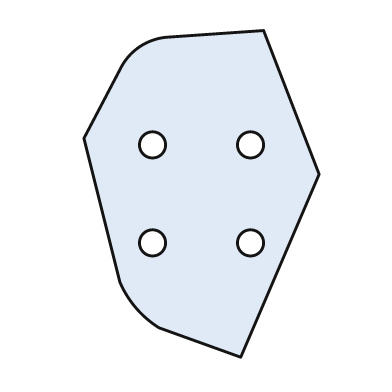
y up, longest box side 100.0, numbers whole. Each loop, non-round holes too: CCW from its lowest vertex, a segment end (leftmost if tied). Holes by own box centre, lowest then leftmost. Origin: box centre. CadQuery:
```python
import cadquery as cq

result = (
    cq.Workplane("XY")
    .moveTo(12.0, -50.0)
    .lineTo(36.0, 6.0)
    .lineTo(19.0, 50.0)
    .lineTo(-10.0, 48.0)
    .threePointArc((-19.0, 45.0), (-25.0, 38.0))
    .lineTo(-36.0, 17.0)
    .lineTo(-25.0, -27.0)
    .threePointArc((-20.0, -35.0), (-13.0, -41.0))
    .close()
    .moveTo(-15.0, -15.0)
    .circle(4.0)
    .moveTo(15.0, -15.0)
    .circle(4.0)
    .moveTo(-15.0, 15.0)
    .circle(4.0)
    .moveTo(15.0, 15.0)
    .circle(4.0)
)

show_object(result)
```